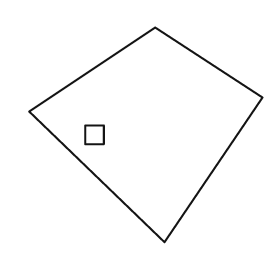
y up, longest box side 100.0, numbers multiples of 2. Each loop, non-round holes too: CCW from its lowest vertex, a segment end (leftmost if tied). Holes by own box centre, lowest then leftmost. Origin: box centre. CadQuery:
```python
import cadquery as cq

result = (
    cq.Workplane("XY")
    .moveTo(8.0, -46.0)
    .lineTo(50.0, 16.0)
    .lineTo(4.0, 46.0)
    .lineTo(-50.0, 10.0)
    .close()
    .moveTo(-26.0, -4.0)
    .lineTo(-18.0, -4.0)
    .lineTo(-18.0, 4.0)
    .lineTo(-26.0, 4.0)
    .close()
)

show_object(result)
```